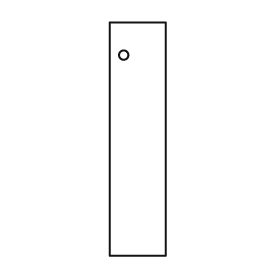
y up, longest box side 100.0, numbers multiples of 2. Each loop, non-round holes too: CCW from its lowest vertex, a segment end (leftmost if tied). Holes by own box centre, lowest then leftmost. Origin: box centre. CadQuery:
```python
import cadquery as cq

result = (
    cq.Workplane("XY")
    .moveTo(-12.0, -50.0)
    .lineTo(12.0, -50.0)
    .lineTo(12.0, 50.0)
    .lineTo(-12.0, 50.0)
    .close()
    .moveTo(-6.0, 36.0)
    .circle(2.0)
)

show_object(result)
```